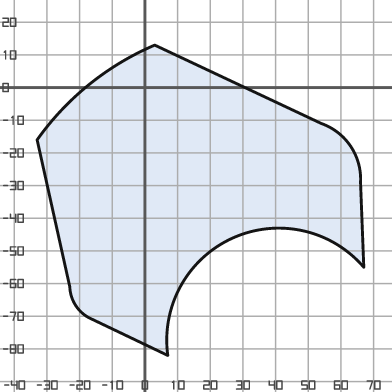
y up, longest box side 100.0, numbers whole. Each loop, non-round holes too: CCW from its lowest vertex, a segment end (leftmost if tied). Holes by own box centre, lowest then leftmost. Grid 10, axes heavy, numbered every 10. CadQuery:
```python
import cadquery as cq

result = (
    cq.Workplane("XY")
    .moveTo(7.0, -82.0)
    .threePointArc((27.0, -46.0), (67.0, -55.0))
    .lineTo(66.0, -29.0)
    .threePointArc((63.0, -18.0), (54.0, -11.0))
    .lineTo(3.0, 13.0)
    .threePointArc((-17.0, 1.0), (-33.0, -16.0))
    .lineTo(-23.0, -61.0)
    .threePointArc((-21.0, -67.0), (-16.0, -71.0))
    .close()
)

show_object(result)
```